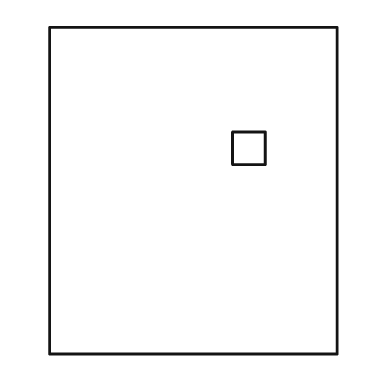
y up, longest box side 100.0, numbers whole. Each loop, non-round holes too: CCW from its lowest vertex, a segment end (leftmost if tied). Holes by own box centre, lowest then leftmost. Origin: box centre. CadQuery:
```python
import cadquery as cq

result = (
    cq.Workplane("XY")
    .moveTo(-44.0, -50.0)
    .lineTo(44.0, -50.0)
    .lineTo(44.0, 50.0)
    .lineTo(-44.0, 50.0)
    .close()
    .moveTo(12.0, 8.0)
    .lineTo(22.0, 8.0)
    .lineTo(22.0, 18.0)
    .lineTo(12.0, 18.0)
    .close()
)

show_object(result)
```